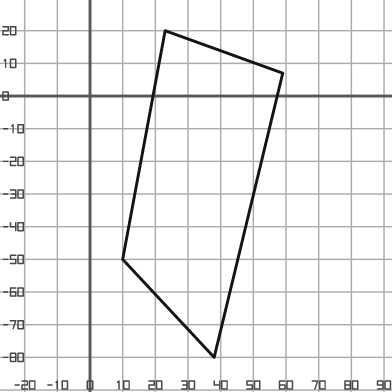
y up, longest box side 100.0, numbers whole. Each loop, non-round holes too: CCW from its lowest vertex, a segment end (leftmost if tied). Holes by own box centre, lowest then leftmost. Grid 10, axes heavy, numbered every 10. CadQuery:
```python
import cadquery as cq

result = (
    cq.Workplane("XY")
    .moveTo(38.0, -80.0)
    .lineTo(59.0, 7.0)
    .lineTo(23.0, 20.0)
    .lineTo(10.0, -50.0)
    .close()
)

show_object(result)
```